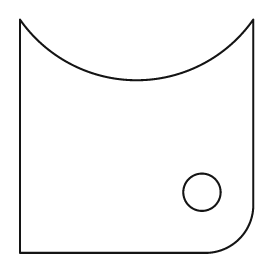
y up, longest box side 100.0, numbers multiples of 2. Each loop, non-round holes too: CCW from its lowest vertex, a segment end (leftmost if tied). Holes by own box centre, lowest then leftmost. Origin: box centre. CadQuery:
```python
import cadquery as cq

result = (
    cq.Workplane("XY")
    .moveTo(-50.0, -50.0)
    .lineTo(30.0, -50.0)
    .threePointArc((44.0, -44.0), (50.0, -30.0))
    .lineTo(50.0, 50.0)
    .threePointArc((0.0, 24.0), (-50.0, 50.0))
    .close()
    .moveTo(28.0, -24.0)
    .circle(8.0)
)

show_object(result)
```